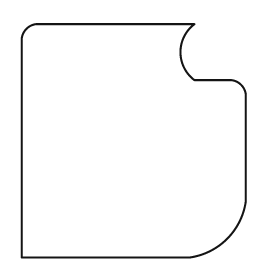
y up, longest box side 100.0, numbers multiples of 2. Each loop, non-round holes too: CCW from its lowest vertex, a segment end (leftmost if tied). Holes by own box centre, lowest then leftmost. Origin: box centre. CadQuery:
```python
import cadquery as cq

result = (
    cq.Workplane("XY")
    .moveTo(-48.0, -50.0)
    .lineTo(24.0, -50.0)
    .threePointArc((40.0, -42.0), (48.0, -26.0))
    .lineTo(48.0, 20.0)
    .threePointArc((46.0, 24.0), (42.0, 26.0))
    .lineTo(26.0, 26.0)
    .threePointArc((20.0, 38.0), (26.0, 50.0))
    .lineTo(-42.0, 50.0)
    .threePointArc((-46.0, 48.0), (-48.0, 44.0))
    .close()
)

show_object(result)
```